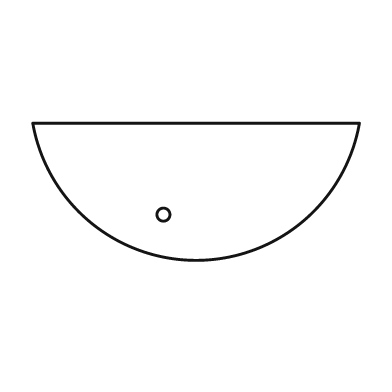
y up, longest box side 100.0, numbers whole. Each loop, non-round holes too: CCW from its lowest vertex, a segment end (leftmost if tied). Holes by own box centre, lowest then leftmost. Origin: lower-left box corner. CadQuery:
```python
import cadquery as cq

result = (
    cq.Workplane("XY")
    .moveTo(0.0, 42.0)
    .threePointArc((50.0, 0.0), (100.0, 42.0))
    .close()
    .moveTo(40.0, 14.0)
    .circle(2.0)
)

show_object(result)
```